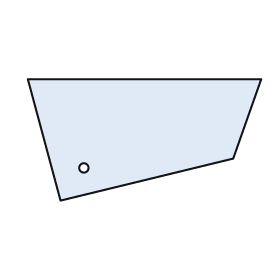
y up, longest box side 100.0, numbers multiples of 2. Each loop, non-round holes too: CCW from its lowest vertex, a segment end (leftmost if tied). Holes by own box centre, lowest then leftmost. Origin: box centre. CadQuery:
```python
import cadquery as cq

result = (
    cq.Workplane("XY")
    .moveTo(-36.0, -26.0)
    .lineTo(38.0, -8.0)
    .lineTo(50.0, 26.0)
    .lineTo(-50.0, 26.0)
    .close()
    .moveTo(-26.0, -12.0)
    .circle(2.0)
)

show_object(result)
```